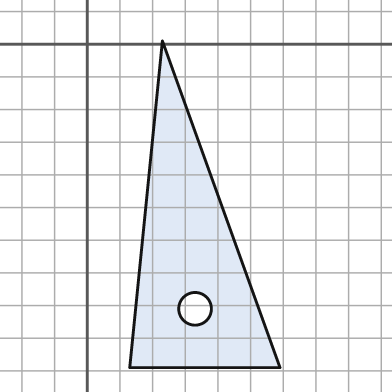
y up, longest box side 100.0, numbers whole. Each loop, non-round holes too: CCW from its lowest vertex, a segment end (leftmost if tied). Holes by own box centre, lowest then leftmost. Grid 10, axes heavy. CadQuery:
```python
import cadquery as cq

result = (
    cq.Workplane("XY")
    .moveTo(13.0, -99.0)
    .lineTo(59.0, -99.0)
    .lineTo(23.0, 1.0)
    .close()
    .moveTo(33.0, -81.0)
    .circle(5.0)
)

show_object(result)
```